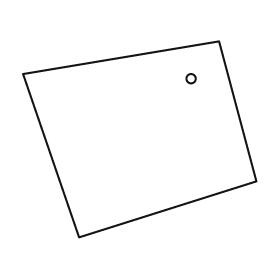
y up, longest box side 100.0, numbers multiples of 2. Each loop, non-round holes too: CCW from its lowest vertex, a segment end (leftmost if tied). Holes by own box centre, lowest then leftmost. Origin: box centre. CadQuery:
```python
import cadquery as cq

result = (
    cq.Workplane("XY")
    .moveTo(-26.0, -42.0)
    .lineTo(50.0, -18.0)
    .lineTo(34.0, 42.0)
    .lineTo(-50.0, 28.0)
    .close()
    .moveTo(22.0, 26.0)
    .circle(2.0)
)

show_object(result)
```